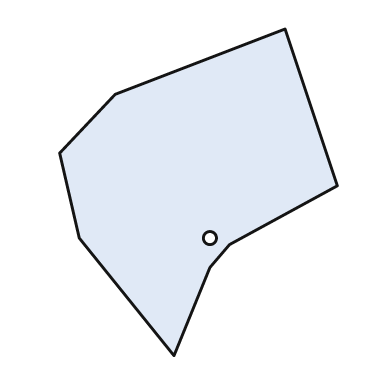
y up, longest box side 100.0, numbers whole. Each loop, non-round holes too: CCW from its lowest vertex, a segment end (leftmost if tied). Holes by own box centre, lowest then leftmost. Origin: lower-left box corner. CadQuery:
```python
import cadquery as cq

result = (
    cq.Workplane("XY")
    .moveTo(35.0, 0.0)
    .lineTo(46.0, 27.0)
    .lineTo(52.0, 34.0)
    .lineTo(85.0, 52.0)
    .lineTo(69.0, 100.0)
    .lineTo(17.0, 80.0)
    .lineTo(0.0, 62.0)
    .lineTo(6.0, 36.0)
    .close()
    .moveTo(46.0, 36.0)
    .circle(2.0)
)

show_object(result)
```